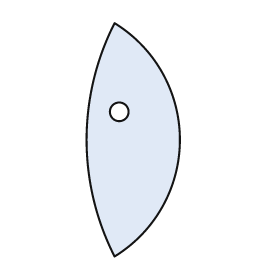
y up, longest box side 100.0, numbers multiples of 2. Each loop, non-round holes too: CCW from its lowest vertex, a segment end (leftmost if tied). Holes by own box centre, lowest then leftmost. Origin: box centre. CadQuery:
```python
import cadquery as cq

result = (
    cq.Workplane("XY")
    .moveTo(-8.0, -50.0)
    .threePointArc((20.0, 0.0), (-8.0, 50.0))
    .threePointArc((-20.0, 0.0), (-8.0, -50.0))
    .close()
    .moveTo(-6.0, 12.0)
    .circle(4.0)
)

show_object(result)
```